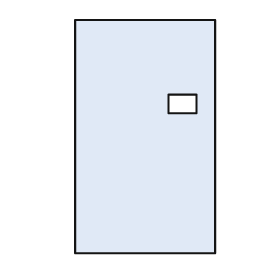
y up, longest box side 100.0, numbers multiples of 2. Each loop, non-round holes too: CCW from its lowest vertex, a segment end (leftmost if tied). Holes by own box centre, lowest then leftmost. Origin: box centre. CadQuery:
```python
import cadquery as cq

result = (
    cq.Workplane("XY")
    .moveTo(-30.0, -50.0)
    .lineTo(30.0, -50.0)
    .lineTo(30.0, 50.0)
    .lineTo(-30.0, 50.0)
    .close()
    .moveTo(10.0, 10.0)
    .lineTo(22.0, 10.0)
    .lineTo(22.0, 18.0)
    .lineTo(10.0, 18.0)
    .close()
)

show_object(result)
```